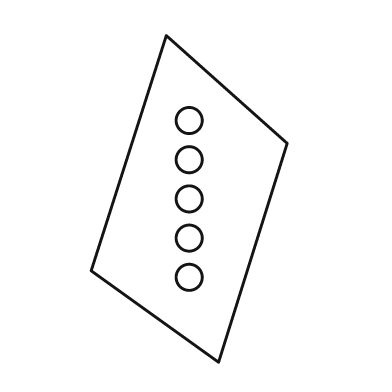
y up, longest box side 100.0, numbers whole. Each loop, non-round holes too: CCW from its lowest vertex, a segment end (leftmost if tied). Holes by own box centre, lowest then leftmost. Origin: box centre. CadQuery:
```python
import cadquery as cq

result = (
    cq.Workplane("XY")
    .moveTo(9.0, -50.0)
    .lineTo(30.0, 17.0)
    .lineTo(-7.0, 50.0)
    .lineTo(-30.0, -22.0)
    .close()
    .moveTo(0.0, -24.0)
    .circle(4.0)
    .moveTo(0.0, -12.0)
    .circle(4.0)
    .moveTo(0.0, 0.0)
    .circle(4.0)
    .moveTo(0.0, 12.0)
    .circle(4.0)
    .moveTo(0.0, 24.0)
    .circle(4.0)
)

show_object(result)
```